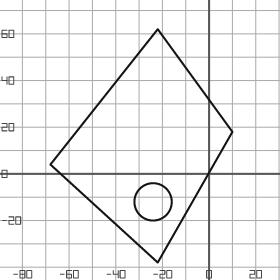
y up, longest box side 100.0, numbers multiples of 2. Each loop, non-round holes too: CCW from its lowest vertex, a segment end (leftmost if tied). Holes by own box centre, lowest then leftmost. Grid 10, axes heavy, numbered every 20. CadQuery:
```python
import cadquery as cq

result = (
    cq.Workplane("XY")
    .moveTo(-22.0, -38.0)
    .lineTo(10.0, 18.0)
    .lineTo(-22.0, 62.0)
    .lineTo(-68.0, 4.0)
    .close()
    .moveTo(-24.0, -12.0)
    .circle(8.0)
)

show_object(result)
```